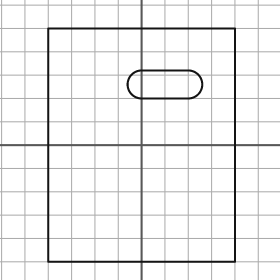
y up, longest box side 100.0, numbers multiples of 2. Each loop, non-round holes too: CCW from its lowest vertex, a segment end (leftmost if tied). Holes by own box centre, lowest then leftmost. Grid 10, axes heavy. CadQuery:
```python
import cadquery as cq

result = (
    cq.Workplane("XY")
    .moveTo(-40.0, -50.0)
    .lineTo(40.0, -50.0)
    .lineTo(40.0, 50.0)
    .lineTo(-40.0, 50.0)
    .close()
    .moveTo(0.0, 20.0)
    .lineTo(20.0, 20.0)
    .threePointArc((26.0, 26.0), (20.0, 32.0))
    .lineTo(0.0, 32.0)
    .threePointArc((-6.0, 26.0), (0.0, 20.0))
    .close()
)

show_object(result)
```